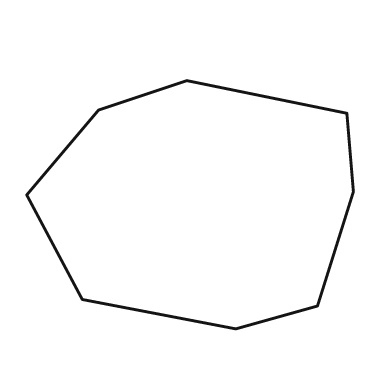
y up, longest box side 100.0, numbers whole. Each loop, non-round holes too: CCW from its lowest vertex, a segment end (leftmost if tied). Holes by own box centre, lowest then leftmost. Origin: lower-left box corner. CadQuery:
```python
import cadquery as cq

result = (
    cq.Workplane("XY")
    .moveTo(64.0, 0.0)
    .lineTo(89.0, 7.0)
    .lineTo(100.0, 42.0)
    .lineTo(98.0, 66.0)
    .lineTo(49.0, 76.0)
    .lineTo(22.0, 67.0)
    .lineTo(0.0, 41.0)
    .lineTo(17.0, 9.0)
    .close()
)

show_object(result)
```